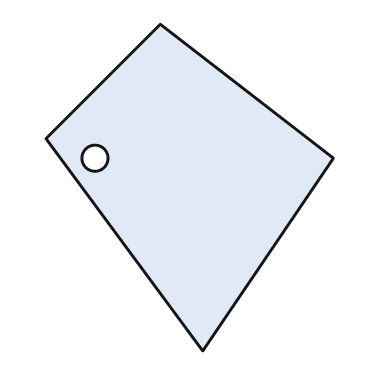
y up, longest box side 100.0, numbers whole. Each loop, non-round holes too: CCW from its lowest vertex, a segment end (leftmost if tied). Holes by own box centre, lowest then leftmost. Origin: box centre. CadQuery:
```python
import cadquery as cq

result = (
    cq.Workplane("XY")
    .moveTo(4.0, -50.0)
    .lineTo(44.0, 9.0)
    .lineTo(-9.0, 50.0)
    .lineTo(-44.0, 15.0)
    .close()
    .moveTo(-29.0, 9.0)
    .circle(4.0)
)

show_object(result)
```